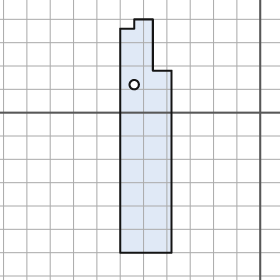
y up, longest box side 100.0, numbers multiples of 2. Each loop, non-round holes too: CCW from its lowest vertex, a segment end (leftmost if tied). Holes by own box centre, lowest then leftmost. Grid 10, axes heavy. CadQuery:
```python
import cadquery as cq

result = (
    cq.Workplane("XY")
    .moveTo(-60.0, -60.0)
    .lineTo(-38.0, -60.0)
    .lineTo(-38.0, 18.0)
    .lineTo(-46.0, 18.0)
    .lineTo(-46.0, 40.0)
    .lineTo(-54.0, 40.0)
    .lineTo(-54.0, 36.0)
    .lineTo(-60.0, 36.0)
    .close()
    .moveTo(-54.0, 12.0)
    .circle(2.0)
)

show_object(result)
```